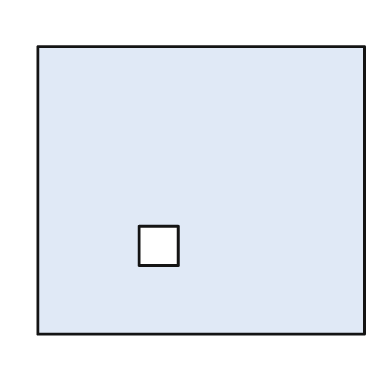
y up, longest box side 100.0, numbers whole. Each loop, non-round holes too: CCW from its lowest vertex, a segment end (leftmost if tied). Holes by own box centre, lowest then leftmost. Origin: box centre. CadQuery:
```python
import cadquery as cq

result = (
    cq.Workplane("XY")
    .moveTo(-50.0, -44.0)
    .lineTo(50.0, -44.0)
    .lineTo(50.0, 44.0)
    .lineTo(-50.0, 44.0)
    .close()
    .moveTo(-19.0, -23.0)
    .lineTo(-7.0, -23.0)
    .lineTo(-7.0, -11.0)
    .lineTo(-19.0, -11.0)
    .close()
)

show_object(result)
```